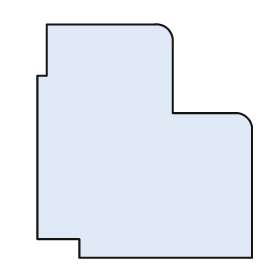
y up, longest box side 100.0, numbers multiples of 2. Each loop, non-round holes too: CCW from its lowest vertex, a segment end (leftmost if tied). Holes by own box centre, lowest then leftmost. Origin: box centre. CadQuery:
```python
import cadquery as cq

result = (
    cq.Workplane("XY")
    .moveTo(-28.0, -50.0)
    .lineTo(46.0, -50.0)
    .lineTo(46.0, 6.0)
    .threePointArc((44.0, 10.0), (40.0, 12.0))
    .lineTo(12.0, 12.0)
    .lineTo(12.0, 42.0)
    .threePointArc((10.0, 48.0), (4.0, 50.0))
    .lineTo(-42.0, 50.0)
    .lineTo(-42.0, 28.0)
    .lineTo(-46.0, 28.0)
    .lineTo(-46.0, -42.0)
    .lineTo(-28.0, -42.0)
    .close()
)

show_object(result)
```